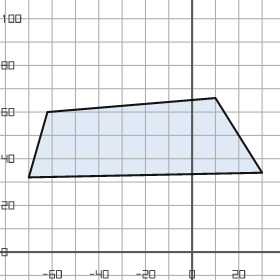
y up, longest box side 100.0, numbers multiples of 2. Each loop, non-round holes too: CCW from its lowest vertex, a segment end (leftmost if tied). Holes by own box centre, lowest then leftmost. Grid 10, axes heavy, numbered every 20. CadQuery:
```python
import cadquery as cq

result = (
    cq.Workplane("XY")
    .moveTo(-70.0, 32.0)
    .lineTo(30.0, 34.0)
    .lineTo(10.0, 66.0)
    .lineTo(-62.0, 60.0)
    .close()
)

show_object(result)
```